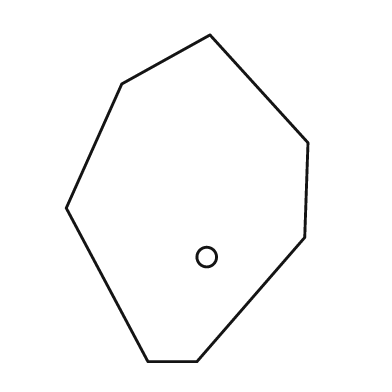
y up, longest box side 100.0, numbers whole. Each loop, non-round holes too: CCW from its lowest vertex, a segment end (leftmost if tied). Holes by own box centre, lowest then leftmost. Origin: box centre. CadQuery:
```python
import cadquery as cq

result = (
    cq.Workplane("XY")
    .moveTo(-12.0, -50.0)
    .lineTo(3.0, -50.0)
    .lineTo(36.0, -12.0)
    .lineTo(37.0, 17.0)
    .lineTo(7.0, 50.0)
    .lineTo(-20.0, 35.0)
    .lineTo(-37.0, -3.0)
    .close()
    .moveTo(6.0, -18.0)
    .circle(3.0)
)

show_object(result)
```